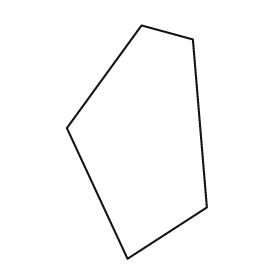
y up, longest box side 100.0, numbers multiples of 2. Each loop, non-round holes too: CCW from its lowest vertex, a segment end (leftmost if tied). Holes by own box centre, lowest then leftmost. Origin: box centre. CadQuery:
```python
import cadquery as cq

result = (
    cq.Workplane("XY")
    .moveTo(-4.0, -50.0)
    .lineTo(30.0, -28.0)
    .lineTo(24.0, 44.0)
    .lineTo(2.0, 50.0)
    .lineTo(-30.0, 6.0)
    .close()
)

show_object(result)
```